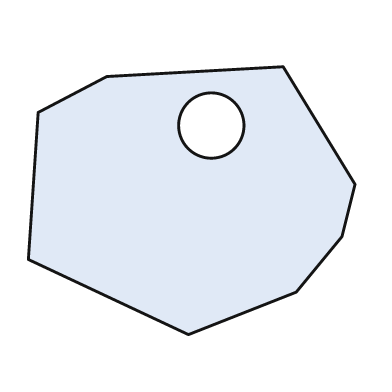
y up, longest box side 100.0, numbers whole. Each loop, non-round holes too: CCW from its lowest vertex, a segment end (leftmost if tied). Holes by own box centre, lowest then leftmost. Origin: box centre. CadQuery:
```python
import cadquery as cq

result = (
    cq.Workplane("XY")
    .moveTo(-1.0, -41.0)
    .lineTo(32.0, -28.0)
    .lineTo(46.0, -11.0)
    .lineTo(50.0, 5.0)
    .lineTo(28.0, 41.0)
    .lineTo(-26.0, 38.0)
    .lineTo(-47.0, 27.0)
    .lineTo(-50.0, -18.0)
    .close()
    .moveTo(6.0, 23.0)
    .circle(10.0)
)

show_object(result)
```